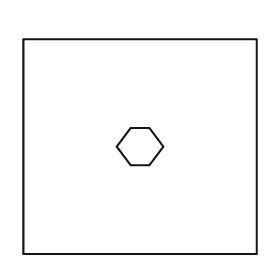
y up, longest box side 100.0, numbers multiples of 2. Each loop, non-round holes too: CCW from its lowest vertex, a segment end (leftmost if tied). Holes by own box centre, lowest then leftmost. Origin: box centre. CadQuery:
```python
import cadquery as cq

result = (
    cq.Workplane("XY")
    .moveTo(-50.0, -46.0)
    .lineTo(50.0, -46.0)
    .lineTo(50.0, 46.0)
    .lineTo(-50.0, 46.0)
    .close()
    .moveTo(-4.0, -8.0)
    .lineTo(4.0, -8.0)
    .lineTo(10.0, 0.0)
    .lineTo(4.0, 8.0)
    .lineTo(-4.0, 8.0)
    .lineTo(-10.0, 0.0)
    .close()
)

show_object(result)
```